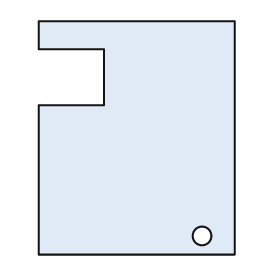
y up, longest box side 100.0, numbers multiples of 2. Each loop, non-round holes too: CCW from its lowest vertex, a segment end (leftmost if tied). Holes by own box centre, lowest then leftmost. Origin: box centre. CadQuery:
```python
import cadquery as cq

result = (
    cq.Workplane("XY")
    .moveTo(-42.0, -50.0)
    .lineTo(42.0, -50.0)
    .lineTo(42.0, 50.0)
    .lineTo(-42.0, 50.0)
    .lineTo(-42.0, 38.0)
    .lineTo(-14.0, 38.0)
    .lineTo(-14.0, 14.0)
    .lineTo(-42.0, 14.0)
    .close()
    .moveTo(28.0, -42.0)
    .circle(4.0)
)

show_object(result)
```